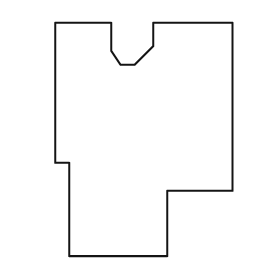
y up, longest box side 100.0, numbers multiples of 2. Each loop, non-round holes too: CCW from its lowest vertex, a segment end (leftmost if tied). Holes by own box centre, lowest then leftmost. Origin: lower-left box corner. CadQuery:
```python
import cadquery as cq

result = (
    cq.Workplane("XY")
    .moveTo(6.0, 0.0)
    .lineTo(48.0, 0.0)
    .lineTo(48.0, 28.0)
    .lineTo(76.0, 28.0)
    .lineTo(76.0, 100.0)
    .lineTo(42.0, 100.0)
    .lineTo(42.0, 90.0)
    .lineTo(34.0, 82.0)
    .lineTo(28.0, 82.0)
    .lineTo(24.0, 88.0)
    .lineTo(24.0, 100.0)
    .lineTo(0.0, 100.0)
    .lineTo(0.0, 40.0)
    .lineTo(6.0, 40.0)
    .close()
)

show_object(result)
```